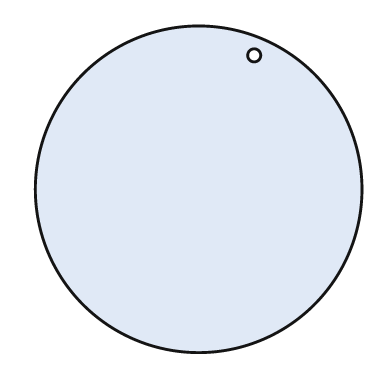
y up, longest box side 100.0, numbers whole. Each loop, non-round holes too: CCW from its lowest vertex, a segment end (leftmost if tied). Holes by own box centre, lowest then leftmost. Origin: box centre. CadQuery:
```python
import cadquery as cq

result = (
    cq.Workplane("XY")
    .moveTo(0.0, 0.0)
    .circle(50.0)
    .moveTo(17.0, 41.0)
    .circle(2.0)
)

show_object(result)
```